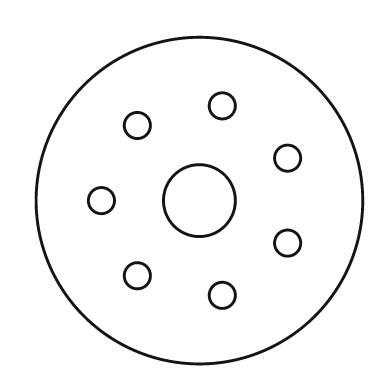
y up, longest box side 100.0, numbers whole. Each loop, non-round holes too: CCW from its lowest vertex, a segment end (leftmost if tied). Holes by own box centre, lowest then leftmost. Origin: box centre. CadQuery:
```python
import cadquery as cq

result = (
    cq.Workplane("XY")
    .moveTo(0.0, 0.0)
    .circle(50.0)
    .moveTo(7.0, -29.0)
    .circle(4.0)
    .moveTo(-19.0, -23.0)
    .circle(4.0)
    .moveTo(27.0, -13.0)
    .circle(4.0)
    .moveTo(-30.0, 0.0)
    .circle(4.0)
    .moveTo(0.0, 0.0)
    .circle(11.0)
    .moveTo(27.0, 13.0)
    .circle(4.0)
    .moveTo(-19.0, 23.0)
    .circle(4.0)
    .moveTo(7.0, 29.0)
    .circle(4.0)
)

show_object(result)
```